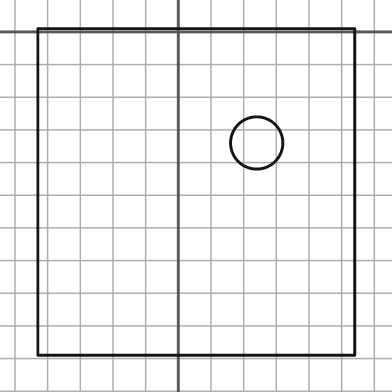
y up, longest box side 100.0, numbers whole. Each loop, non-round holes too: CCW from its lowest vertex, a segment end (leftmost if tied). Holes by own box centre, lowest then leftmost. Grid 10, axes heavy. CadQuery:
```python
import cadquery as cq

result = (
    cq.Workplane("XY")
    .moveTo(-43.0, -99.0)
    .lineTo(54.0, -99.0)
    .lineTo(54.0, 1.0)
    .lineTo(-43.0, 1.0)
    .close()
    .moveTo(24.0, -34.0)
    .circle(8.0)
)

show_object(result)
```